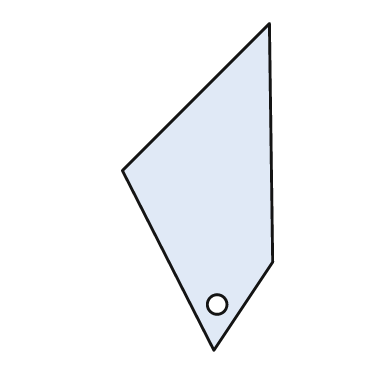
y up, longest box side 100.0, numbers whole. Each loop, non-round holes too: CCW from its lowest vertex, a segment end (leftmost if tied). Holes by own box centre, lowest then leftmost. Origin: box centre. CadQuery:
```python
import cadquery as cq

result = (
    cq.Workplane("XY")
    .moveTo(5.0, -50.0)
    .lineTo(23.0, -23.0)
    .lineTo(22.0, 50.0)
    .lineTo(-23.0, 5.0)
    .close()
    .moveTo(6.0, -36.0)
    .circle(3.0)
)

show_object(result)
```